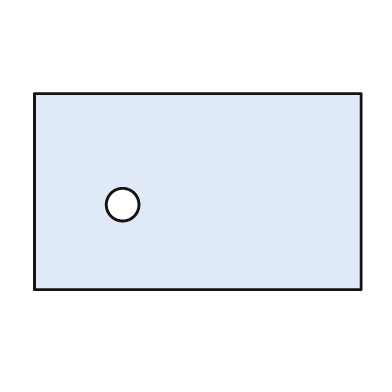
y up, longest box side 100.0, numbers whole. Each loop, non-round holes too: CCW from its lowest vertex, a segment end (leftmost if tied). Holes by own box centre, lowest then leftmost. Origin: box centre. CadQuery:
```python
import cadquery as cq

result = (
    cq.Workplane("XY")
    .moveTo(-50.0, -30.0)
    .lineTo(50.0, -30.0)
    .lineTo(50.0, 30.0)
    .lineTo(-50.0, 30.0)
    .close()
    .moveTo(-23.0, -4.0)
    .circle(5.0)
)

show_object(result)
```